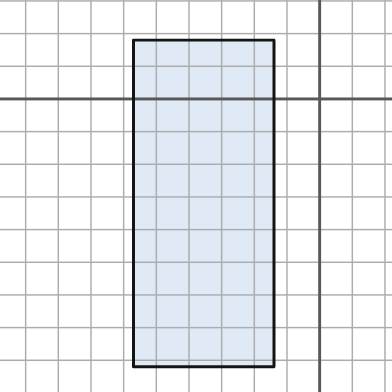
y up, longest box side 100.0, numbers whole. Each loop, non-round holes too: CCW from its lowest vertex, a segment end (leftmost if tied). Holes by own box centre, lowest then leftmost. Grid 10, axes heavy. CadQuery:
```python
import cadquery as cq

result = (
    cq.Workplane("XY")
    .moveTo(-57.0, -82.0)
    .lineTo(-14.0, -82.0)
    .lineTo(-14.0, 18.0)
    .lineTo(-57.0, 18.0)
    .close()
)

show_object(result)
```